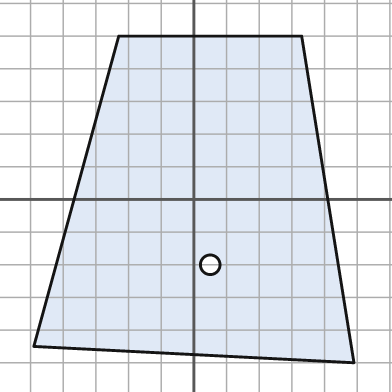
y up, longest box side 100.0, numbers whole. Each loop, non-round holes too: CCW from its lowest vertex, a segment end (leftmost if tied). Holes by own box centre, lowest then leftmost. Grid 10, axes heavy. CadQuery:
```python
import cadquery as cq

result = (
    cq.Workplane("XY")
    .moveTo(49.0, -50.0)
    .lineTo(33.0, 50.0)
    .lineTo(-23.0, 50.0)
    .lineTo(-49.0, -45.0)
    .close()
    .moveTo(5.0, -20.0)
    .circle(3.0)
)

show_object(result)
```